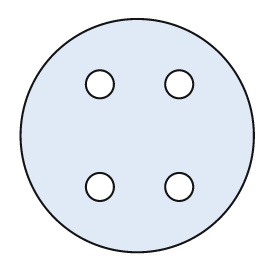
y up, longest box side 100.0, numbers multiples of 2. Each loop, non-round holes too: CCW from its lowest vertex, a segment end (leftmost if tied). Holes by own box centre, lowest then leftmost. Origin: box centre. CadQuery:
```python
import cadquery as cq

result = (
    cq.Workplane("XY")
    .moveTo(0.0, 0.0)
    .circle(50.0)
    .moveTo(-16.0, -22.0)
    .circle(6.0)
    .moveTo(18.0, -22.0)
    .circle(6.0)
    .moveTo(-16.0, 22.0)
    .circle(6.0)
    .moveTo(18.0, 22.0)
    .circle(6.0)
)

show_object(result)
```